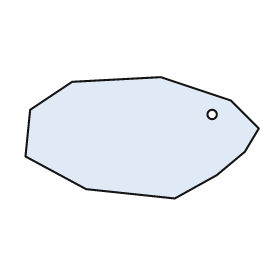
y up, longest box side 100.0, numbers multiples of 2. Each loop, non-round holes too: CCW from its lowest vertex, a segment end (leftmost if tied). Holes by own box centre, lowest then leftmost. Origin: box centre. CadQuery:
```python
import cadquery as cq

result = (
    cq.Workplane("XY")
    .moveTo(14.0, -26.0)
    .lineTo(32.0, -16.0)
    .lineTo(44.0, -6.0)
    .lineTo(50.0, 4.0)
    .lineTo(38.0, 16.0)
    .lineTo(8.0, 26.0)
    .lineTo(-30.0, 24.0)
    .lineTo(-48.0, 12.0)
    .lineTo(-50.0, -8.0)
    .lineTo(-24.0, -22.0)
    .close()
    .moveTo(30.0, 10.0)
    .circle(2.0)
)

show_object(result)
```